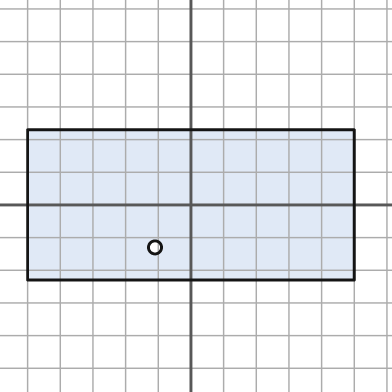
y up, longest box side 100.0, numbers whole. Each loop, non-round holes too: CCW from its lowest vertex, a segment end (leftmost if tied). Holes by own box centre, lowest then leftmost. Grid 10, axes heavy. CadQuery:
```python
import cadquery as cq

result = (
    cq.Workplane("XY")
    .moveTo(-50.0, -23.0)
    .lineTo(50.0, -23.0)
    .lineTo(50.0, 23.0)
    .lineTo(-50.0, 23.0)
    .close()
    .moveTo(-11.0, -13.0)
    .circle(2.0)
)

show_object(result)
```